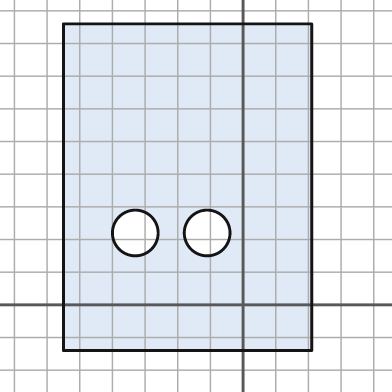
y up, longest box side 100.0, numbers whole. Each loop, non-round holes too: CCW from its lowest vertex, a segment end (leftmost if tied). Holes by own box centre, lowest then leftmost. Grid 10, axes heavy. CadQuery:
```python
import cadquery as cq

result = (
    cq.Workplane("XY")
    .moveTo(-55.0, -14.0)
    .lineTo(21.0, -14.0)
    .lineTo(21.0, 86.0)
    .lineTo(-55.0, 86.0)
    .close()
    .moveTo(-33.0, 22.0)
    .circle(7.0)
    .moveTo(-11.0, 22.0)
    .circle(7.0)
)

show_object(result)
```